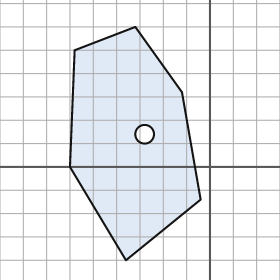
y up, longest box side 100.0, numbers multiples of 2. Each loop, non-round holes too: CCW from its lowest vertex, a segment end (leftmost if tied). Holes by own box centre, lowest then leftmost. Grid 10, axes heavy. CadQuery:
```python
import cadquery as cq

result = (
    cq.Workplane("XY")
    .moveTo(-36.0, -40.0)
    .lineTo(-4.0, -14.0)
    .lineTo(-12.0, 32.0)
    .lineTo(-32.0, 60.0)
    .lineTo(-58.0, 50.0)
    .lineTo(-60.0, 0.0)
    .close()
    .moveTo(-28.0, 14.0)
    .circle(4.0)
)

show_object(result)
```